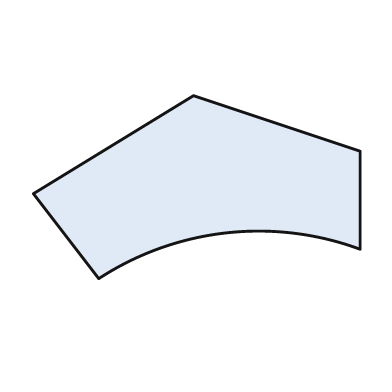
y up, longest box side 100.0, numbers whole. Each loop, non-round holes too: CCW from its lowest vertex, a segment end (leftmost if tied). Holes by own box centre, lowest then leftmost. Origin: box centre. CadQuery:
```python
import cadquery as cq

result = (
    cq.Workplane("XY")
    .moveTo(-30.0, -28.0)
    .threePointArc((9.0, -14.0), (50.0, -19.0))
    .lineTo(50.0, 11.0)
    .lineTo(-1.0, 28.0)
    .lineTo(-50.0, -2.0)
    .close()
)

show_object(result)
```